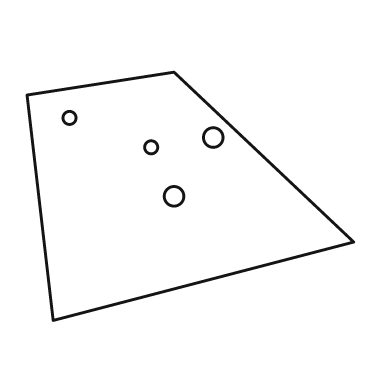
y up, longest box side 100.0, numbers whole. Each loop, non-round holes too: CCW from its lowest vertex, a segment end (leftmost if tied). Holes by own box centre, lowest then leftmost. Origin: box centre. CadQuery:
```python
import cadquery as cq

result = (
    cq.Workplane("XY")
    .moveTo(-42.0, -38.0)
    .lineTo(50.0, -14.0)
    .lineTo(-5.0, 38.0)
    .lineTo(-50.0, 31.0)
    .close()
    .moveTo(-5.0, 0.0)
    .circle(3.0)
    .moveTo(-12.0, 15.0)
    .circle(2.0)
    .moveTo(7.0, 18.0)
    .circle(3.0)
    .moveTo(-37.0, 24.0)
    .circle(2.0)
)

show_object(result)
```